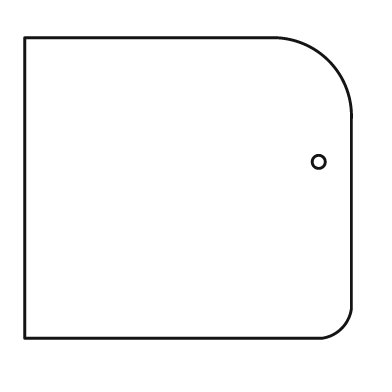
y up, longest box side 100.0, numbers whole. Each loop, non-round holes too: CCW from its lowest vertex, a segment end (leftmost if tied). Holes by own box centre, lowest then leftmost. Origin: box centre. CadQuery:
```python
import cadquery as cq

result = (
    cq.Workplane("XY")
    .moveTo(-50.0, -46.0)
    .lineTo(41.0, -46.0)
    .threePointArc((47.0, -43.0), (50.0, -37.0))
    .lineTo(50.0, 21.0)
    .threePointArc((43.0, 39.0), (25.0, 46.0))
    .lineTo(-50.0, 46.0)
    .close()
    .moveTo(40.0, 8.0)
    .circle(2.0)
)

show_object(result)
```